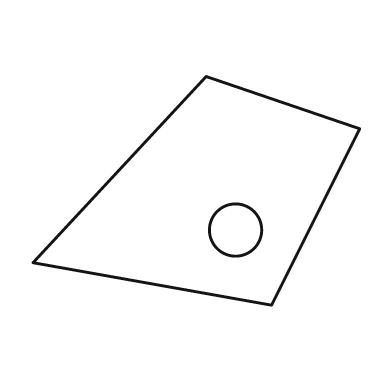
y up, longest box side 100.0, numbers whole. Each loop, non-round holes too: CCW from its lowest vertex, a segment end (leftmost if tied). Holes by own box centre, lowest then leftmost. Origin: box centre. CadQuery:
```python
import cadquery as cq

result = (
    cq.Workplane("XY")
    .moveTo(23.0, -35.0)
    .lineTo(50.0, 19.0)
    .lineTo(3.0, 35.0)
    .lineTo(-50.0, -22.0)
    .close()
    .moveTo(12.0, -12.0)
    .circle(8.0)
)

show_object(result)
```